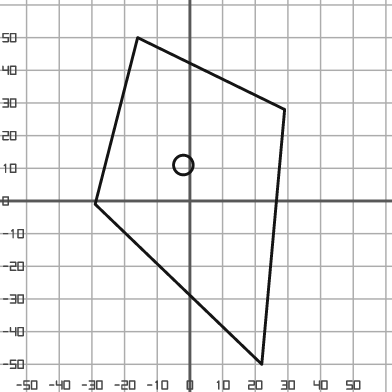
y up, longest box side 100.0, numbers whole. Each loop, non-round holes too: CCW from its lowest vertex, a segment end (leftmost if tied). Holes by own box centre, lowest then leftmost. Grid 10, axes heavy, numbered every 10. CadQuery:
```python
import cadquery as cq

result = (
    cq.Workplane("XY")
    .moveTo(22.0, -50.0)
    .lineTo(29.0, 28.0)
    .lineTo(-16.0, 50.0)
    .lineTo(-29.0, -1.0)
    .close()
    .moveTo(-2.0, 11.0)
    .circle(3.0)
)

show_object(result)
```